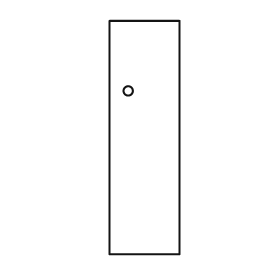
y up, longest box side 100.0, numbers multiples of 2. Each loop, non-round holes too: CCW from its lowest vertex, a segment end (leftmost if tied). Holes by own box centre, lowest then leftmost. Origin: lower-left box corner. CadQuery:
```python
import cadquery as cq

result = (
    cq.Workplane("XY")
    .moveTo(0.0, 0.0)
    .lineTo(30.0, 0.0)
    .lineTo(30.0, 100.0)
    .lineTo(0.0, 100.0)
    .close()
    .moveTo(8.0, 70.0)
    .circle(2.0)
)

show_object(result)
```